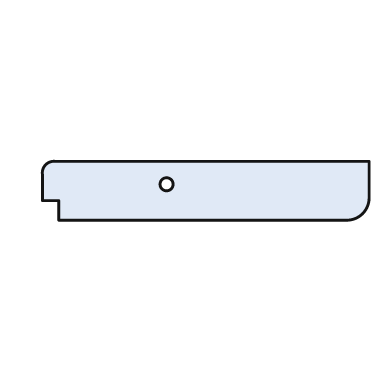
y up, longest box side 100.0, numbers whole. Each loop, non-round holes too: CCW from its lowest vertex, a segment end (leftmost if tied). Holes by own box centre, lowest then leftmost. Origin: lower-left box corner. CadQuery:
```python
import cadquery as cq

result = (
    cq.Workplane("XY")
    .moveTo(5.0, 0.0)
    .lineTo(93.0, 0.0)
    .threePointArc((98.0, 2.0), (100.0, 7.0))
    .lineTo(100.0, 18.0)
    .lineTo(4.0, 18.0)
    .threePointArc((1.0, 17.0), (0.0, 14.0))
    .lineTo(0.0, 6.0)
    .lineTo(5.0, 6.0)
    .close()
    .moveTo(38.0, 11.0)
    .circle(2.0)
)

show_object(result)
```